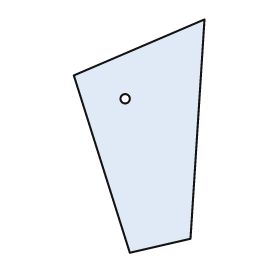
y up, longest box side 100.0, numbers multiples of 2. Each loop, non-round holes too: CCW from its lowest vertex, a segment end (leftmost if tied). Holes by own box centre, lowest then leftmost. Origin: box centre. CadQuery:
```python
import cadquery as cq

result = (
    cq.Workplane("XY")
    .moveTo(-4.0, -50.0)
    .lineTo(22.0, -44.0)
    .lineTo(28.0, 50.0)
    .lineTo(-28.0, 26.0)
    .close()
    .moveTo(-6.0, 16.0)
    .circle(2.0)
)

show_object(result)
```